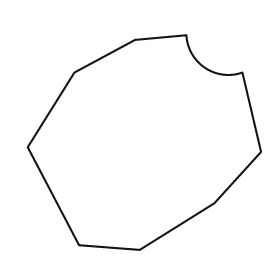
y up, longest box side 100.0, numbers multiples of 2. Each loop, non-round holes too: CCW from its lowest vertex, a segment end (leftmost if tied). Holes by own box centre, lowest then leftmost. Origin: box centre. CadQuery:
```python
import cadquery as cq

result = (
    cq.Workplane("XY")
    .moveTo(-2.0, -46.0)
    .lineTo(30.0, -26.0)
    .lineTo(50.0, -4.0)
    .lineTo(42.0, 30.0)
    .threePointArc((26.0, 32.0), (18.0, 46.0))
    .lineTo(-4.0, 44.0)
    .lineTo(-30.0, 30.0)
    .lineTo(-50.0, -2.0)
    .lineTo(-28.0, -44.0)
    .close()
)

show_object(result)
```